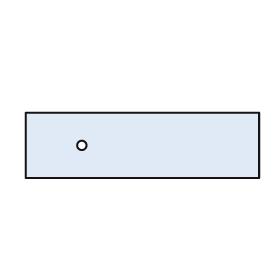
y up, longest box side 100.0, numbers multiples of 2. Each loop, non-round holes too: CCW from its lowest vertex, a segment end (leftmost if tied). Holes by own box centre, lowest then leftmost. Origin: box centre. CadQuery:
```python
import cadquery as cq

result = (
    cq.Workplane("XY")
    .moveTo(-50.0, -14.0)
    .lineTo(50.0, -14.0)
    .lineTo(50.0, 14.0)
    .lineTo(-50.0, 14.0)
    .close()
    .moveTo(-26.0, 0.0)
    .circle(2.0)
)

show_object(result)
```